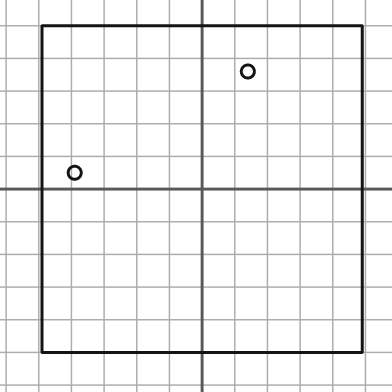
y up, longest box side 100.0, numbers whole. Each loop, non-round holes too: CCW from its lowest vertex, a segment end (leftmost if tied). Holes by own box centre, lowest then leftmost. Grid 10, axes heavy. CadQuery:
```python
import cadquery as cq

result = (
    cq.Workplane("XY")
    .moveTo(-49.0, -50.0)
    .lineTo(49.0, -50.0)
    .lineTo(49.0, 50.0)
    .lineTo(-49.0, 50.0)
    .close()
    .moveTo(-39.0, 5.0)
    .circle(2.0)
    .moveTo(14.0, 36.0)
    .circle(2.0)
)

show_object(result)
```